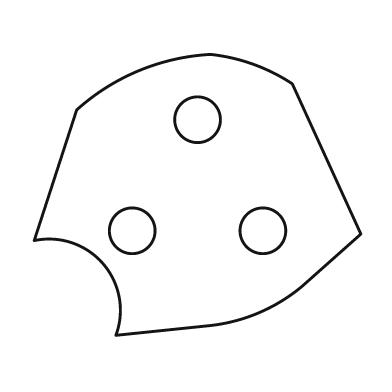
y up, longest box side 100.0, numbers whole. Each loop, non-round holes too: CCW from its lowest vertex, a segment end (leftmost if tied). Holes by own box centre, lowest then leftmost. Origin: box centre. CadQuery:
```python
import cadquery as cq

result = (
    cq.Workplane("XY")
    .moveTo(-25.0, -43.0)
    .lineTo(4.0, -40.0)
    .threePointArc((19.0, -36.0), (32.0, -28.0))
    .lineTo(50.0, -12.0)
    .lineTo(29.0, 34.0)
    .threePointArc((17.0, 40.0), (4.0, 43.0))
    .threePointArc((-18.0, 38.0), (-37.0, 26.0))
    .lineTo(-50.0, -14.0)
    .threePointArc((-29.0, -21.0), (-25.0, -43.0))
    .close()
    .moveTo(-20.0, -11.0)
    .circle(7.0)
    .moveTo(20.0, -11.0)
    .circle(7.0)
    .moveTo(0.0, 23.0)
    .circle(7.0)
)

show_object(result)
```